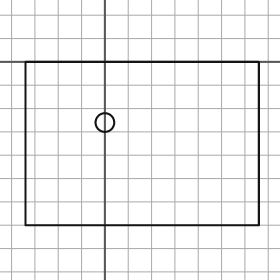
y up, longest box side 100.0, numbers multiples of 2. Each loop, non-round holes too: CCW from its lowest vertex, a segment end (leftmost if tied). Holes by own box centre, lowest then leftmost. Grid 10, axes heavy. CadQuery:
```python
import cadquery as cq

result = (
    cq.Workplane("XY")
    .moveTo(-34.0, -70.0)
    .lineTo(66.0, -70.0)
    .lineTo(66.0, 0.0)
    .lineTo(-34.0, 0.0)
    .close()
    .moveTo(0.0, -26.0)
    .circle(4.0)
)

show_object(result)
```